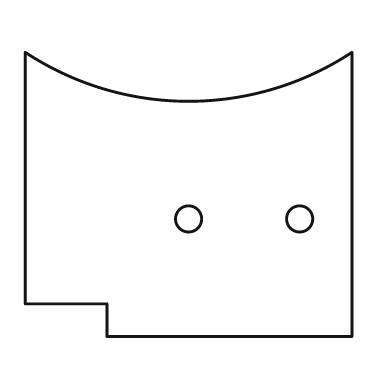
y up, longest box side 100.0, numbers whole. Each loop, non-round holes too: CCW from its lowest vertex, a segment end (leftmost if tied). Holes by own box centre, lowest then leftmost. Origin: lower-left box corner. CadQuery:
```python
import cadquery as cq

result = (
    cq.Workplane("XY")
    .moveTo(25.0, 0.0)
    .lineTo(100.0, 0.0)
    .lineTo(100.0, 87.0)
    .threePointArc((50.0, 72.0), (0.0, 87.0))
    .lineTo(0.0, 10.0)
    .lineTo(25.0, 10.0)
    .close()
    .moveTo(50.0, 36.0)
    .circle(4.0)
    .moveTo(84.0, 36.0)
    .circle(4.0)
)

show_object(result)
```